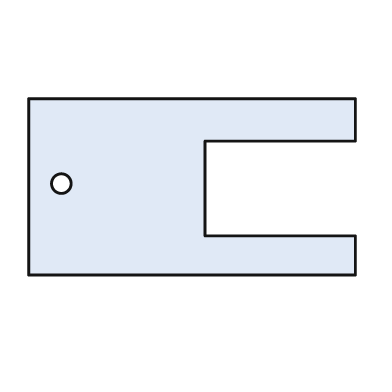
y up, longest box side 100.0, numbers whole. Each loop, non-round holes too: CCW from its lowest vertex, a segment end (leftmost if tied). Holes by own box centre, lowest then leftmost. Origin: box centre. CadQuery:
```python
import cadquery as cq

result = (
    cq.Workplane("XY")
    .moveTo(-50.0, -27.0)
    .lineTo(50.0, -27.0)
    .lineTo(50.0, -15.0)
    .lineTo(4.0, -15.0)
    .lineTo(4.0, 14.0)
    .lineTo(50.0, 14.0)
    .lineTo(50.0, 27.0)
    .lineTo(-50.0, 27.0)
    .close()
    .moveTo(-40.0, 1.0)
    .circle(3.0)
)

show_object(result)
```